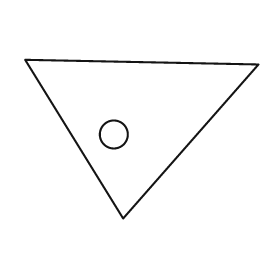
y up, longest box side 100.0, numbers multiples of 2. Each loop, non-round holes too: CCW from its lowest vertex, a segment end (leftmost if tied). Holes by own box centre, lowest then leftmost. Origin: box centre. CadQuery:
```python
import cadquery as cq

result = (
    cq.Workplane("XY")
    .moveTo(-8.0, -34.0)
    .lineTo(50.0, 32.0)
    .lineTo(-50.0, 34.0)
    .close()
    .moveTo(-12.0, 2.0)
    .circle(6.0)
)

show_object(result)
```